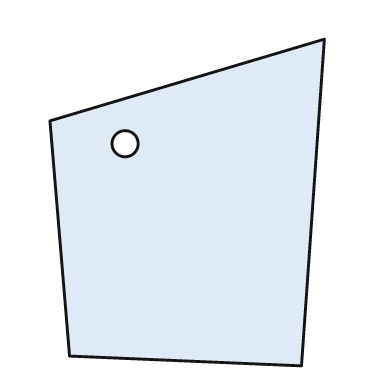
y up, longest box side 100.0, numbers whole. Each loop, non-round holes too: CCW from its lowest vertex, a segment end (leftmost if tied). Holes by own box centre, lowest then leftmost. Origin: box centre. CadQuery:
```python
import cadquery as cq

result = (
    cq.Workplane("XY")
    .moveTo(35.0, -50.0)
    .lineTo(42.0, 50.0)
    .lineTo(-42.0, 25.0)
    .lineTo(-36.0, -47.0)
    .close()
    .moveTo(-19.0, 18.0)
    .circle(4.0)
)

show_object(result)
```